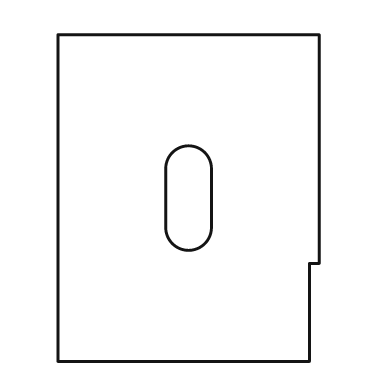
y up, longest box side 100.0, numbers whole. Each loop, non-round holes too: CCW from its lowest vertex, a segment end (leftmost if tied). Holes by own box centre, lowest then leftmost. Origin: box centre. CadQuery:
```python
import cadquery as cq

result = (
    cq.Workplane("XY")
    .moveTo(-40.0, -50.0)
    .lineTo(37.0, -50.0)
    .lineTo(37.0, -20.0)
    .lineTo(40.0, -20.0)
    .lineTo(40.0, 50.0)
    .lineTo(-40.0, 50.0)
    .close()
    .moveTo(-7.0, -9.0)
    .threePointArc((0.0, -16.0), (7.0, -9.0))
    .lineTo(7.0, 9.0)
    .threePointArc((0.0, 16.0), (-7.0, 9.0))
    .close()
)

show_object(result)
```